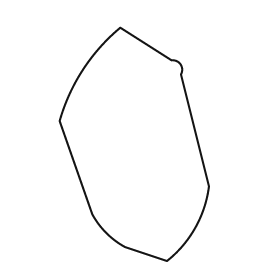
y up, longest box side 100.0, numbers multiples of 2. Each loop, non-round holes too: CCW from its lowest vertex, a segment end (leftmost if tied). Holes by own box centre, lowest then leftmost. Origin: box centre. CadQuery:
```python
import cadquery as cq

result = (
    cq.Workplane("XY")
    .moveTo(14.0, -50.0)
    .threePointArc((26.0, -36.0), (32.0, -18.0))
    .lineTo(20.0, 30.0)
    .threePointArc((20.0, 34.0), (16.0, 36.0))
    .lineTo(-6.0, 50.0)
    .threePointArc((-22.0, 32.0), (-32.0, 10.0))
    .lineTo(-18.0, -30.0)
    .threePointArc((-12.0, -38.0), (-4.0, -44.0))
    .close()
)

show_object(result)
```